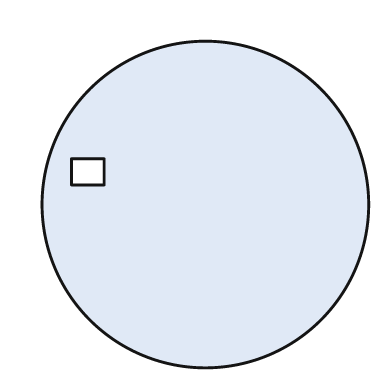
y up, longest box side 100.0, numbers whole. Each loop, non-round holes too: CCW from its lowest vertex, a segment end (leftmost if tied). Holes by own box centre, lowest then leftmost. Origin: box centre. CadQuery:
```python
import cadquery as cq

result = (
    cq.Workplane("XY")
    .moveTo(0.0, 0.0)
    .circle(50.0)
    .moveTo(-41.0, 6.0)
    .lineTo(-31.0, 6.0)
    .lineTo(-31.0, 14.0)
    .lineTo(-41.0, 14.0)
    .close()
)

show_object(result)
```